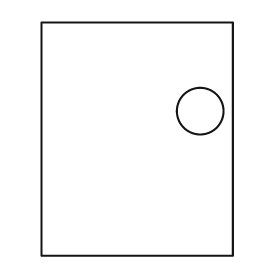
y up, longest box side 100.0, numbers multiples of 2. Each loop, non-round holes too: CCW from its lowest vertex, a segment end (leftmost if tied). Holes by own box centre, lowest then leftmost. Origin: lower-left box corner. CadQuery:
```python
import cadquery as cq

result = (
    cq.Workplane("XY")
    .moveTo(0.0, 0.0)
    .lineTo(82.0, 0.0)
    .lineTo(82.0, 100.0)
    .lineTo(0.0, 100.0)
    .close()
    .moveTo(68.0, 62.0)
    .circle(10.0)
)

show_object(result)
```